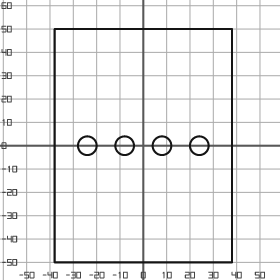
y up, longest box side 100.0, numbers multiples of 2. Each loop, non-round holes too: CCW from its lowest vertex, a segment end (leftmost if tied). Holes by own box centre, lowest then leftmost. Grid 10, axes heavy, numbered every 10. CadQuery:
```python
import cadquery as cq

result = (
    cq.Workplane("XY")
    .moveTo(-38.0, -50.0)
    .lineTo(38.0, -50.0)
    .lineTo(38.0, 50.0)
    .lineTo(-38.0, 50.0)
    .close()
    .moveTo(-24.0, 0.0)
    .circle(4.0)
    .moveTo(-8.0, 0.0)
    .circle(4.0)
    .moveTo(8.0, 0.0)
    .circle(4.0)
    .moveTo(24.0, 0.0)
    .circle(4.0)
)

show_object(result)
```